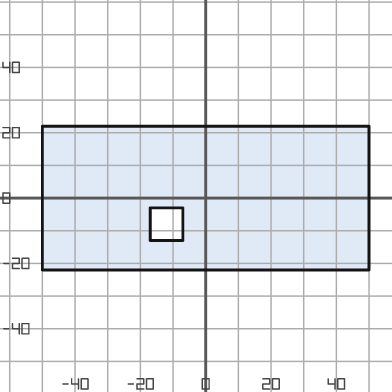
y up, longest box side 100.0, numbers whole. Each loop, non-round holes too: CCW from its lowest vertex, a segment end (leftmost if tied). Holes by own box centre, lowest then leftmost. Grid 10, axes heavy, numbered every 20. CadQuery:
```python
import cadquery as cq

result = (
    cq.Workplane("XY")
    .moveTo(-50.0, -22.0)
    .lineTo(50.0, -22.0)
    .lineTo(50.0, 22.0)
    .lineTo(-50.0, 22.0)
    .close()
    .moveTo(-17.0, -13.0)
    .lineTo(-7.0, -13.0)
    .lineTo(-7.0, -3.0)
    .lineTo(-17.0, -3.0)
    .close()
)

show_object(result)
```